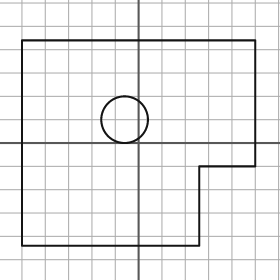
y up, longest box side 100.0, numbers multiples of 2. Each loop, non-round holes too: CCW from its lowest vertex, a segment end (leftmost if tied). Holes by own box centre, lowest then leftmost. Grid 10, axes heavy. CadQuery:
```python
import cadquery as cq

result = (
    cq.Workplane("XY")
    .moveTo(-50.0, -44.0)
    .lineTo(26.0, -44.0)
    .lineTo(26.0, -10.0)
    .lineTo(50.0, -10.0)
    .lineTo(50.0, 44.0)
    .lineTo(-50.0, 44.0)
    .close()
    .moveTo(-6.0, 10.0)
    .circle(10.0)
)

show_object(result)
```